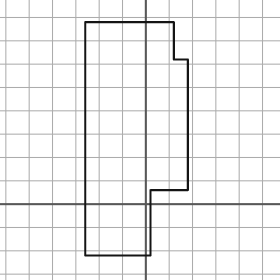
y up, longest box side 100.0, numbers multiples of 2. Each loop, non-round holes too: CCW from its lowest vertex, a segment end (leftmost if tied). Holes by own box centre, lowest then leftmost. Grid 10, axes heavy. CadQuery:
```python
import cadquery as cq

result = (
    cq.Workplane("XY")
    .moveTo(-26.0, -22.0)
    .lineTo(2.0, -22.0)
    .lineTo(2.0, 6.0)
    .lineTo(18.0, 6.0)
    .lineTo(18.0, 62.0)
    .lineTo(12.0, 62.0)
    .lineTo(12.0, 78.0)
    .lineTo(-26.0, 78.0)
    .close()
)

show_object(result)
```